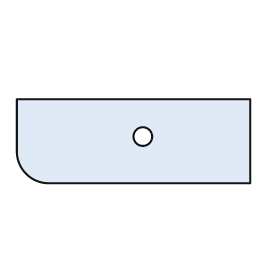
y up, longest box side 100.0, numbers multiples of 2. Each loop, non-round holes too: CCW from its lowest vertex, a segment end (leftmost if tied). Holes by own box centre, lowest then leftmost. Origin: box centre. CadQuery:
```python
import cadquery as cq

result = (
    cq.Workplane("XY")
    .moveTo(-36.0, -18.0)
    .lineTo(50.0, -18.0)
    .lineTo(50.0, 18.0)
    .lineTo(-50.0, 18.0)
    .lineTo(-50.0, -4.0)
    .threePointArc((-46.0, -14.0), (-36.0, -18.0))
    .close()
    .moveTo(4.0, 2.0)
    .circle(4.0)
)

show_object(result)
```